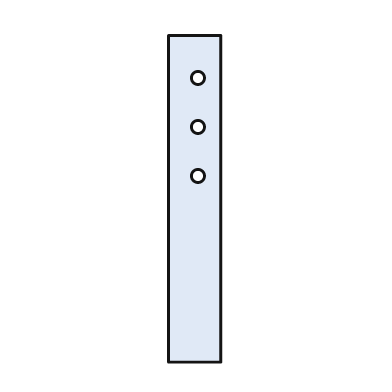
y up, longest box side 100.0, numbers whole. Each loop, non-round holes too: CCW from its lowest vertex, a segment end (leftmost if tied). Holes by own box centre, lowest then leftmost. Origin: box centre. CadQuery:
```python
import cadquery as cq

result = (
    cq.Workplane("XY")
    .moveTo(-8.0, -50.0)
    .lineTo(8.0, -50.0)
    .lineTo(8.0, 50.0)
    .lineTo(-8.0, 50.0)
    .close()
    .moveTo(1.0, 7.0)
    .circle(2.0)
    .moveTo(1.0, 22.0)
    .circle(2.0)
    .moveTo(1.0, 37.0)
    .circle(2.0)
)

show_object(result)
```